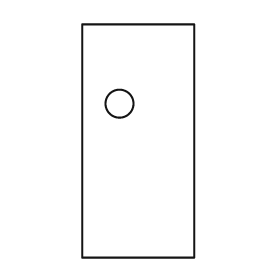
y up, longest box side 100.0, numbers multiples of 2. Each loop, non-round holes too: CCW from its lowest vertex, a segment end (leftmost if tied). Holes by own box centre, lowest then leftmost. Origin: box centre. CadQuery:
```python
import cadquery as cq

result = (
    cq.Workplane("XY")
    .moveTo(-24.0, -50.0)
    .lineTo(24.0, -50.0)
    .lineTo(24.0, 50.0)
    .lineTo(-24.0, 50.0)
    .close()
    .moveTo(-8.0, 16.0)
    .circle(6.0)
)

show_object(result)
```